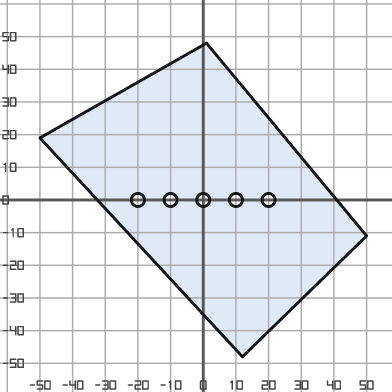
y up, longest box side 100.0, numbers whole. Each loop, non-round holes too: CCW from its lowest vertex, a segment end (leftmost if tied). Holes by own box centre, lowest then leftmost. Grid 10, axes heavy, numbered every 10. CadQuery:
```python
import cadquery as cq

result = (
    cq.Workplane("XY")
    .moveTo(12.0, -48.0)
    .lineTo(50.0, -11.0)
    .lineTo(1.0, 48.0)
    .lineTo(-50.0, 19.0)
    .close()
    .moveTo(-20.0, 0.0)
    .circle(2.0)
    .moveTo(-10.0, 0.0)
    .circle(2.0)
    .moveTo(0.0, 0.0)
    .circle(2.0)
    .moveTo(10.0, 0.0)
    .circle(2.0)
    .moveTo(20.0, 0.0)
    .circle(2.0)
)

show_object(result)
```